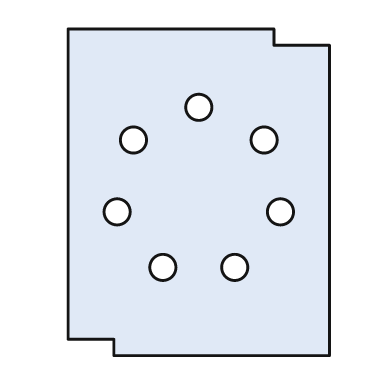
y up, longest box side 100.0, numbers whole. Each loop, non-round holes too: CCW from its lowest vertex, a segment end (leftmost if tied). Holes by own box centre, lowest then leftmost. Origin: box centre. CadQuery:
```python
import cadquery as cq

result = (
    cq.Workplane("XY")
    .moveTo(-26.0, -50.0)
    .lineTo(40.0, -50.0)
    .lineTo(40.0, 45.0)
    .lineTo(23.0, 45.0)
    .lineTo(23.0, 50.0)
    .lineTo(-40.0, 50.0)
    .lineTo(-40.0, -45.0)
    .lineTo(-26.0, -45.0)
    .close()
    .moveTo(-11.0, -23.0)
    .circle(4.0)
    .moveTo(11.0, -23.0)
    .circle(4.0)
    .moveTo(-25.0, -6.0)
    .circle(4.0)
    .moveTo(25.0, -6.0)
    .circle(4.0)
    .moveTo(-20.0, 16.0)
    .circle(4.0)
    .moveTo(20.0, 16.0)
    .circle(4.0)
    .moveTo(0.0, 26.0)
    .circle(4.0)
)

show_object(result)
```